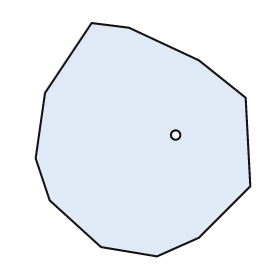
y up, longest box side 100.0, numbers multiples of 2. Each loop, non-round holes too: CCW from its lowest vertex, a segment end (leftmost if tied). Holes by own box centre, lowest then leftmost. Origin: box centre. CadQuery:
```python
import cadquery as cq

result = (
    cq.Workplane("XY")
    .moveTo(6.0, -50.0)
    .lineTo(24.0, -42.0)
    .lineTo(46.0, -20.0)
    .lineTo(44.0, 18.0)
    .lineTo(24.0, 34.0)
    .lineTo(-6.0, 48.0)
    .lineTo(-22.0, 50.0)
    .lineTo(-42.0, 20.0)
    .lineTo(-46.0, -8.0)
    .lineTo(-40.0, -26.0)
    .lineTo(-18.0, -46.0)
    .close()
    .moveTo(14.0, 2.0)
    .circle(2.0)
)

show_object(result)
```